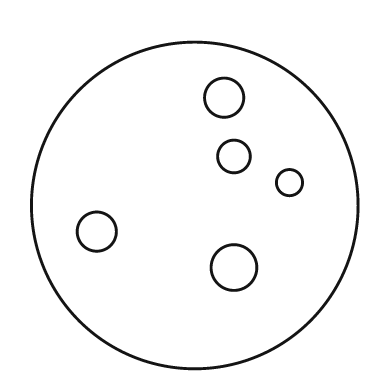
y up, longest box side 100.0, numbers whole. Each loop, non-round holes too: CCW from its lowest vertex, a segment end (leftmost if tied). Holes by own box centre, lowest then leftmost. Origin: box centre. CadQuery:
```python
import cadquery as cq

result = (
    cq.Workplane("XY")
    .moveTo(0.0, 0.0)
    .circle(50.0)
    .moveTo(12.0, -19.0)
    .circle(7.0)
    .moveTo(-30.0, -8.0)
    .circle(6.0)
    .moveTo(29.0, 7.0)
    .circle(4.0)
    .moveTo(12.0, 15.0)
    .circle(5.0)
    .moveTo(9.0, 33.0)
    .circle(6.0)
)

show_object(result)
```